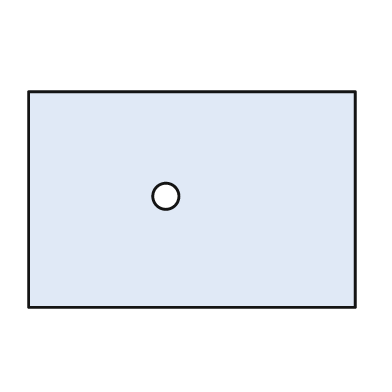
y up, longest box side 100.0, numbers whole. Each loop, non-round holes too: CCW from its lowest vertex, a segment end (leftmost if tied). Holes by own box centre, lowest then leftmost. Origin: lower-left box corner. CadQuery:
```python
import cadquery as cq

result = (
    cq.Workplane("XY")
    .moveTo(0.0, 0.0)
    .lineTo(100.0, 0.0)
    .lineTo(100.0, 66.0)
    .lineTo(0.0, 66.0)
    .close()
    .moveTo(42.0, 34.0)
    .circle(4.0)
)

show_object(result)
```